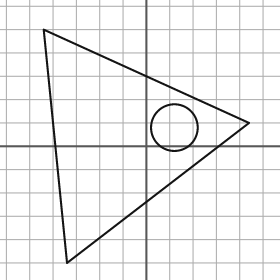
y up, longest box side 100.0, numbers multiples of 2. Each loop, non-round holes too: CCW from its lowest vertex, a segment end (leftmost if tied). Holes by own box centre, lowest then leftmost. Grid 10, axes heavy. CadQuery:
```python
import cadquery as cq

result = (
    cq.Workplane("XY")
    .moveTo(-34.0, -50.0)
    .lineTo(44.0, 10.0)
    .lineTo(-44.0, 50.0)
    .close()
    .moveTo(12.0, 8.0)
    .circle(10.0)
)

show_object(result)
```